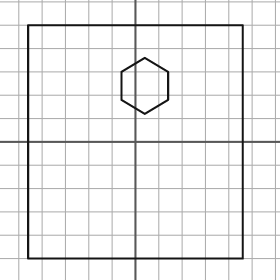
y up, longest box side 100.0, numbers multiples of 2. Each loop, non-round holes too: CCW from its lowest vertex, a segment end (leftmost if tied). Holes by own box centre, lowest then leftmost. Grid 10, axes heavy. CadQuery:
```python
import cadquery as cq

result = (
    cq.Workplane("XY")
    .moveTo(-46.0, -50.0)
    .lineTo(46.0, -50.0)
    .lineTo(46.0, 50.0)
    .lineTo(-46.0, 50.0)
    .close()
    .moveTo(4.0, 12.0)
    .lineTo(14.0, 18.0)
    .lineTo(14.0, 30.0)
    .lineTo(4.0, 36.0)
    .lineTo(-6.0, 30.0)
    .lineTo(-6.0, 18.0)
    .close()
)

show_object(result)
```